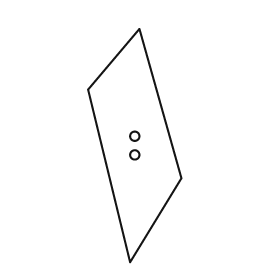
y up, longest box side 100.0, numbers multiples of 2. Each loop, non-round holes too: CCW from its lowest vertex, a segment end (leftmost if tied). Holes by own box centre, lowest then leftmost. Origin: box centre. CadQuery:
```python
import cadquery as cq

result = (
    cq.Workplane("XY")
    .moveTo(-2.0, -50.0)
    .lineTo(20.0, -14.0)
    .lineTo(2.0, 50.0)
    .lineTo(-20.0, 24.0)
    .close()
    .moveTo(0.0, -4.0)
    .circle(2.0)
    .moveTo(0.0, 4.0)
    .circle(2.0)
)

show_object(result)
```